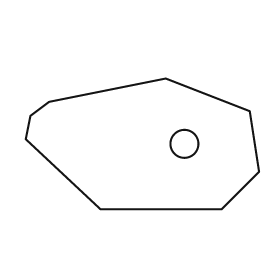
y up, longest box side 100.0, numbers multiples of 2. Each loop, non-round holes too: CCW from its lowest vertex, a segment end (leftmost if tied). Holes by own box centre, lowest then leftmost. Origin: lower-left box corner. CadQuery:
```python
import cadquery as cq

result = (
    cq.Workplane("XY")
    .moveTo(32.0, 0.0)
    .lineTo(84.0, 0.0)
    .lineTo(100.0, 16.0)
    .lineTo(96.0, 42.0)
    .lineTo(60.0, 56.0)
    .lineTo(10.0, 46.0)
    .lineTo(2.0, 40.0)
    .lineTo(0.0, 30.0)
    .close()
    .moveTo(68.0, 28.0)
    .circle(6.0)
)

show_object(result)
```